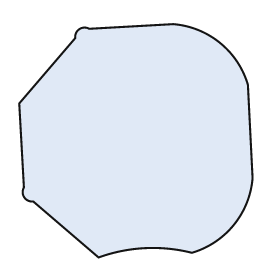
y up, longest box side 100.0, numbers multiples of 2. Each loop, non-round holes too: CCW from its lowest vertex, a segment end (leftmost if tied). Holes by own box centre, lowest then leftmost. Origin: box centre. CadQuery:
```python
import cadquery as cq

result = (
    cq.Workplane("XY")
    .moveTo(-16.0, -50.0)
    .threePointArc((4.0, -46.0), (24.0, -48.0))
    .threePointArc((42.0, -36.0), (50.0, -16.0))
    .lineTo(48.0, 24.0)
    .threePointArc((36.0, 42.0), (16.0, 50.0))
    .lineTo(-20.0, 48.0)
    .threePointArc((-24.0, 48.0), (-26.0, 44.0))
    .lineTo(-50.0, 16.0)
    .lineTo(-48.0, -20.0)
    .threePointArc((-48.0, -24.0), (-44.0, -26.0))
    .close()
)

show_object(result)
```